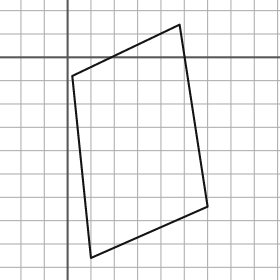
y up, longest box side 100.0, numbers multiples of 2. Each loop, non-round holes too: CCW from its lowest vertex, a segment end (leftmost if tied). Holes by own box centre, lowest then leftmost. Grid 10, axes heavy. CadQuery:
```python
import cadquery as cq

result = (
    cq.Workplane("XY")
    .moveTo(10.0, -86.0)
    .lineTo(60.0, -64.0)
    .lineTo(48.0, 14.0)
    .lineTo(2.0, -8.0)
    .close()
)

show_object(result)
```